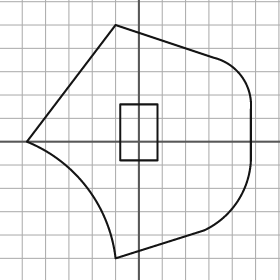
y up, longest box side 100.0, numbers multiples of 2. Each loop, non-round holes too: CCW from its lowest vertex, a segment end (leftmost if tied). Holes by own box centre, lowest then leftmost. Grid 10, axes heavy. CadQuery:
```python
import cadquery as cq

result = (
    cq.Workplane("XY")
    .moveTo(-10.0, -50.0)
    .lineTo(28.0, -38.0)
    .threePointArc((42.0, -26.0), (48.0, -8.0))
    .lineTo(48.0, 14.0)
    .threePointArc((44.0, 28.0), (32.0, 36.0))
    .lineTo(-10.0, 50.0)
    .lineTo(-48.0, 0.0)
    .threePointArc((-22.0, -20.0), (-10.0, -50.0))
    .close()
    .moveTo(-8.0, -8.0)
    .lineTo(8.0, -8.0)
    .lineTo(8.0, 16.0)
    .lineTo(-8.0, 16.0)
    .close()
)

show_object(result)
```